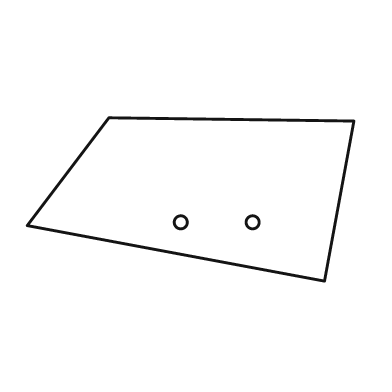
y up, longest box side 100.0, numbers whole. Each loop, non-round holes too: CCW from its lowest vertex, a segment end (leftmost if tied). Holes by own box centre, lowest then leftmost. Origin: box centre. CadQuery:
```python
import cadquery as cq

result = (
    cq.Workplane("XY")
    .moveTo(41.0, -25.0)
    .lineTo(50.0, 24.0)
    .lineTo(-25.0, 25.0)
    .lineTo(-50.0, -8.0)
    .close()
    .moveTo(-3.0, -7.0)
    .circle(2.0)
    .moveTo(19.0, -7.0)
    .circle(2.0)
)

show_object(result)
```